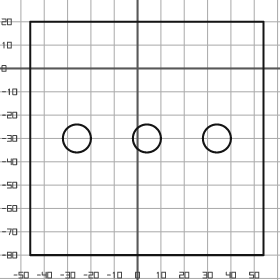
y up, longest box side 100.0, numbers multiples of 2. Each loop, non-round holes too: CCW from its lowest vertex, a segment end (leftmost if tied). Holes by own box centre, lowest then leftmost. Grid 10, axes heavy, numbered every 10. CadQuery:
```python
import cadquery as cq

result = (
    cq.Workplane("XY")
    .moveTo(-46.0, -80.0)
    .lineTo(54.0, -80.0)
    .lineTo(54.0, 20.0)
    .lineTo(-46.0, 20.0)
    .close()
    .moveTo(-26.0, -30.0)
    .circle(6.0)
    .moveTo(4.0, -30.0)
    .circle(6.0)
    .moveTo(34.0, -30.0)
    .circle(6.0)
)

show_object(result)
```